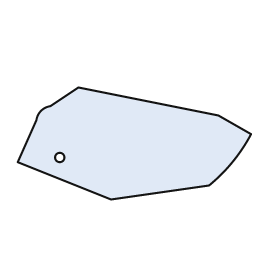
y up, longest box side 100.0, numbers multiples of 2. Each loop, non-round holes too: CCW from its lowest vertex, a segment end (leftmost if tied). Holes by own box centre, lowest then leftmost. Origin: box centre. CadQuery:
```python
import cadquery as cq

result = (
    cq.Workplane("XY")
    .moveTo(-10.0, -24.0)
    .lineTo(32.0, -18.0)
    .threePointArc((42.0, -8.0), (50.0, 4.0))
    .lineTo(36.0, 12.0)
    .lineTo(-24.0, 24.0)
    .lineTo(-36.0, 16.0)
    .threePointArc((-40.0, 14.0), (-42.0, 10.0))
    .lineTo(-50.0, -8.0)
    .close()
    .moveTo(-32.0, -6.0)
    .circle(2.0)
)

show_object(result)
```